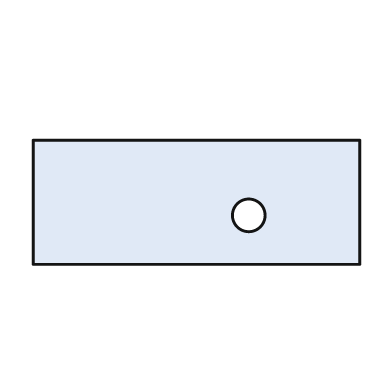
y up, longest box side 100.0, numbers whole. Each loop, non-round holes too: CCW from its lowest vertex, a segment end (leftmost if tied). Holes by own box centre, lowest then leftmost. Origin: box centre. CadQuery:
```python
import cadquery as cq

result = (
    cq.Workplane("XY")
    .moveTo(-50.0, -19.0)
    .lineTo(50.0, -19.0)
    .lineTo(50.0, 19.0)
    .lineTo(-50.0, 19.0)
    .close()
    .moveTo(16.0, -4.0)
    .circle(5.0)
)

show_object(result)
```